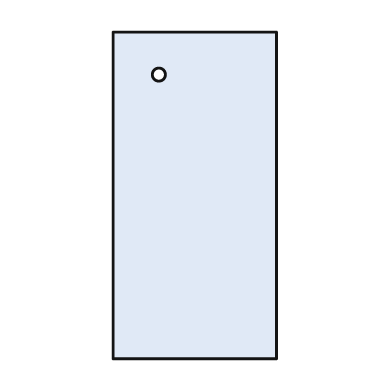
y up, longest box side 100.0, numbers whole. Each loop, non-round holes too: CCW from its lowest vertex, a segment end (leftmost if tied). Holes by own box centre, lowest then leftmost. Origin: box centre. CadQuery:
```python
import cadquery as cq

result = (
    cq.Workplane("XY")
    .moveTo(-25.0, -50.0)
    .lineTo(25.0, -50.0)
    .lineTo(25.0, 50.0)
    .lineTo(-25.0, 50.0)
    .close()
    .moveTo(-11.0, 37.0)
    .circle(2.0)
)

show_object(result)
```